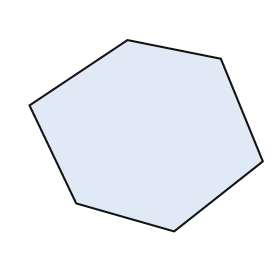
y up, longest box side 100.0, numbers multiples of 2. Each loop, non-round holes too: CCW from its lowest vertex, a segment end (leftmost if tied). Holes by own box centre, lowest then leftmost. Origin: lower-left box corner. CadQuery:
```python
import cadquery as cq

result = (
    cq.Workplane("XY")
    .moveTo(62.0, 0.0)
    .lineTo(100.0, 30.0)
    .lineTo(82.0, 74.0)
    .lineTo(42.0, 82.0)
    .lineTo(0.0, 54.0)
    .lineTo(20.0, 12.0)
    .close()
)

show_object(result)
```